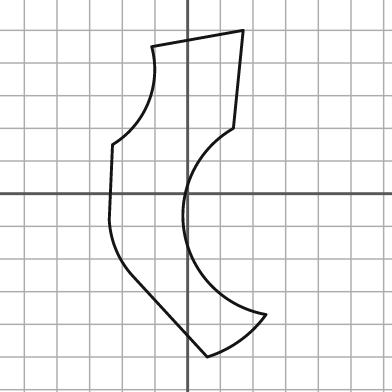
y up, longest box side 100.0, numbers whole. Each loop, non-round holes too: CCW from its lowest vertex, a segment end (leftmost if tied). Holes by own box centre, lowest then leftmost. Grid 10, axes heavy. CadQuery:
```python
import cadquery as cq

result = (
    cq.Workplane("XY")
    .moveTo(6.0, -50.0)
    .threePointArc((16.0, -45.0), (24.0, -37.0))
    .threePointArc((-1.0, -12.0), (14.0, 20.0))
    .lineTo(17.0, 50.0)
    .lineTo(-11.0, 45.0)
    .threePointArc((-12.0, 28.0), (-23.0, 15.0))
    .lineTo(-24.0, -8.0)
    .threePointArc((-22.0, -17.0), (-17.0, -25.0))
    .close()
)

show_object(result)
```